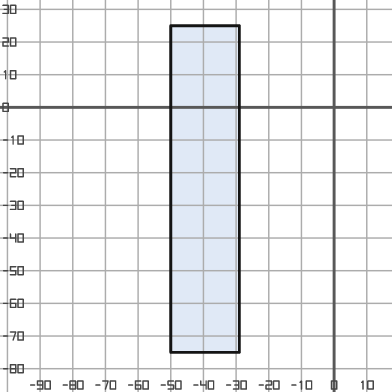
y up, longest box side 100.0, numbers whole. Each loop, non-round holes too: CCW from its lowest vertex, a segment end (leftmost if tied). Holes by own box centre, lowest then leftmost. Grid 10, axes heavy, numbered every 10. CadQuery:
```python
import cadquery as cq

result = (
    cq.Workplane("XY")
    .moveTo(-50.0, -75.0)
    .lineTo(-29.0, -75.0)
    .lineTo(-29.0, 25.0)
    .lineTo(-50.0, 25.0)
    .close()
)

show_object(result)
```